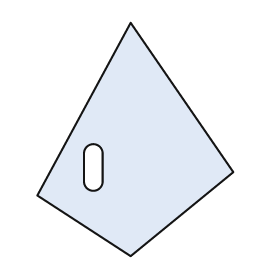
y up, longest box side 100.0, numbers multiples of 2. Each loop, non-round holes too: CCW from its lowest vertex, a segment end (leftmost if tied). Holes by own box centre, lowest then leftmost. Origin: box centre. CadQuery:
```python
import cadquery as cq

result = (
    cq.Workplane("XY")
    .moveTo(-2.0, -50.0)
    .lineTo(42.0, -14.0)
    .lineTo(-2.0, 50.0)
    .lineTo(-42.0, -24.0)
    .close()
    .moveTo(-22.0, -18.0)
    .threePointArc((-18.0, -22.0), (-14.0, -18.0))
    .lineTo(-14.0, -6.0)
    .threePointArc((-18.0, -2.0), (-22.0, -6.0))
    .close()
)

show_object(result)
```